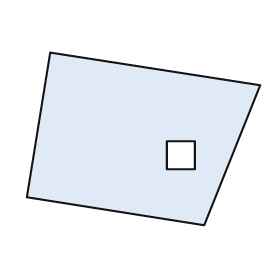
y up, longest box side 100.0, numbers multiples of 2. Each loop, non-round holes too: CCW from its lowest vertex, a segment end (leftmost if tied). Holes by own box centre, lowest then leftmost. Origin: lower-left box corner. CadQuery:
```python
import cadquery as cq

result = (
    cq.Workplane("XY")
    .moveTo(76.0, 0.0)
    .lineTo(100.0, 60.0)
    .lineTo(10.0, 74.0)
    .lineTo(0.0, 12.0)
    .close()
    .moveTo(60.0, 24.0)
    .lineTo(72.0, 24.0)
    .lineTo(72.0, 36.0)
    .lineTo(60.0, 36.0)
    .close()
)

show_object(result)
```